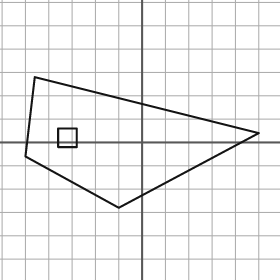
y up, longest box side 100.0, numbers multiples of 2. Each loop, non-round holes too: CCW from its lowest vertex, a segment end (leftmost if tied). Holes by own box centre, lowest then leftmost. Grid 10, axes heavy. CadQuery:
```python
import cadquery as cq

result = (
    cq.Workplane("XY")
    .moveTo(-10.0, -28.0)
    .lineTo(50.0, 4.0)
    .lineTo(-46.0, 28.0)
    .lineTo(-50.0, -6.0)
    .close()
    .moveTo(-36.0, -2.0)
    .lineTo(-28.0, -2.0)
    .lineTo(-28.0, 6.0)
    .lineTo(-36.0, 6.0)
    .close()
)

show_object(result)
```